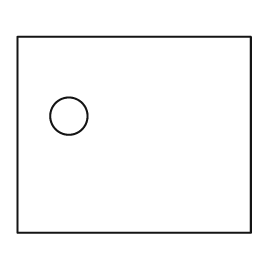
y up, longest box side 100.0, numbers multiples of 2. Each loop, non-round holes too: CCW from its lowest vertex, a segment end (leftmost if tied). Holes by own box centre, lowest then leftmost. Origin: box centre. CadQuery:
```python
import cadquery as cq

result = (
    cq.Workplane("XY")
    .moveTo(-50.0, -42.0)
    .lineTo(50.0, -42.0)
    .lineTo(50.0, 42.0)
    .lineTo(-50.0, 42.0)
    .close()
    .moveTo(-28.0, 8.0)
    .circle(8.0)
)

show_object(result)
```